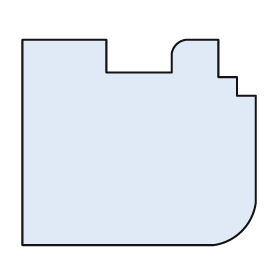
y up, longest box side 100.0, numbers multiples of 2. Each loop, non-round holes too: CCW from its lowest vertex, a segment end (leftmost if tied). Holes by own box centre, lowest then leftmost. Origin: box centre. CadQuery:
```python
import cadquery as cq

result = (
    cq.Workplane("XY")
    .moveTo(-50.0, -44.0)
    .lineTo(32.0, -44.0)
    .threePointArc((44.0, -38.0), (50.0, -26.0))
    .lineTo(50.0, 20.0)
    .lineTo(42.0, 20.0)
    .lineTo(42.0, 28.0)
    .lineTo(34.0, 28.0)
    .lineTo(34.0, 44.0)
    .lineTo(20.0, 44.0)
    .threePointArc((16.0, 42.0), (14.0, 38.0))
    .lineTo(14.0, 30.0)
    .lineTo(-14.0, 30.0)
    .lineTo(-14.0, 44.0)
    .lineTo(-50.0, 44.0)
    .close()
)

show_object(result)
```